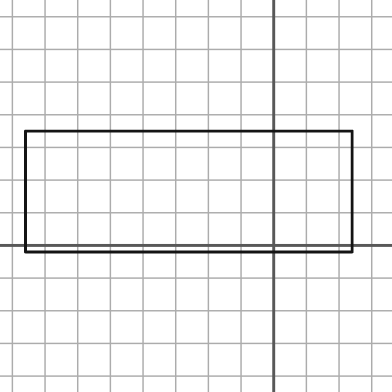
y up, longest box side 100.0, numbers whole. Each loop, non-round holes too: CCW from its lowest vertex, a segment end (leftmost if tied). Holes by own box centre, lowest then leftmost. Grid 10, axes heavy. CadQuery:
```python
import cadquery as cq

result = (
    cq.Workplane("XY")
    .moveTo(-76.0, -2.0)
    .lineTo(24.0, -2.0)
    .lineTo(24.0, 35.0)
    .lineTo(-76.0, 35.0)
    .close()
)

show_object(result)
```